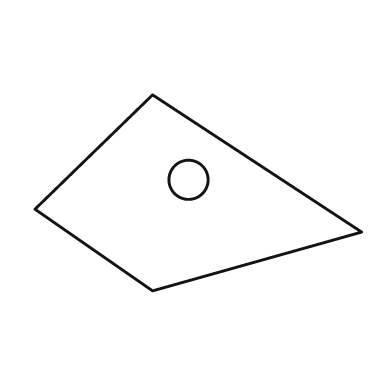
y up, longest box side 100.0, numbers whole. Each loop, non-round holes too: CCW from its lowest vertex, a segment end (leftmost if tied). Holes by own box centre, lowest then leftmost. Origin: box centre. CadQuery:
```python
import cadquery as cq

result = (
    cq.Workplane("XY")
    .moveTo(-14.0, -30.0)
    .lineTo(50.0, -12.0)
    .lineTo(-14.0, 30.0)
    .lineTo(-50.0, -5.0)
    .close()
    .moveTo(-3.0, 4.0)
    .circle(6.0)
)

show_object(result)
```